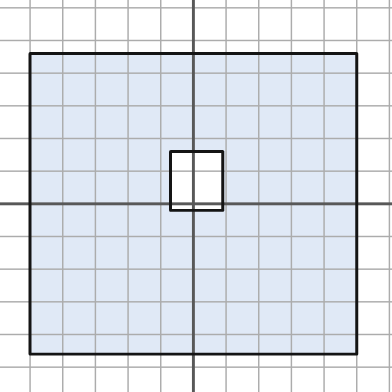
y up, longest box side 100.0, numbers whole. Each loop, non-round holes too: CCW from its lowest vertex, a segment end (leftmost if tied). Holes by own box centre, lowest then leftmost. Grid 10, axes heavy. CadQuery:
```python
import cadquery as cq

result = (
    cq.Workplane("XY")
    .moveTo(-50.0, -46.0)
    .lineTo(50.0, -46.0)
    .lineTo(50.0, 46.0)
    .lineTo(-50.0, 46.0)
    .close()
    .moveTo(-7.0, -2.0)
    .lineTo(9.0, -2.0)
    .lineTo(9.0, 16.0)
    .lineTo(-7.0, 16.0)
    .close()
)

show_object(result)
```